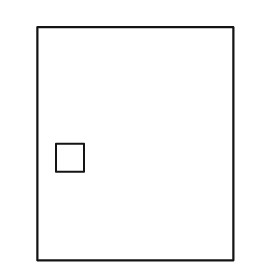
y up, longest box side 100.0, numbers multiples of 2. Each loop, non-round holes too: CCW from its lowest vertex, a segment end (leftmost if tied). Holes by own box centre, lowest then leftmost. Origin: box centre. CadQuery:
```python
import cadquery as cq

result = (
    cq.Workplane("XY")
    .moveTo(-42.0, -50.0)
    .lineTo(42.0, -50.0)
    .lineTo(42.0, 50.0)
    .lineTo(-42.0, 50.0)
    .close()
    .moveTo(-34.0, -12.0)
    .lineTo(-22.0, -12.0)
    .lineTo(-22.0, 0.0)
    .lineTo(-34.0, 0.0)
    .close()
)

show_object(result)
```